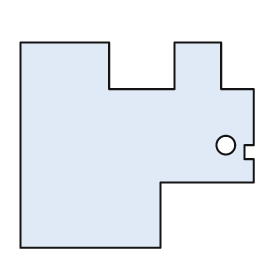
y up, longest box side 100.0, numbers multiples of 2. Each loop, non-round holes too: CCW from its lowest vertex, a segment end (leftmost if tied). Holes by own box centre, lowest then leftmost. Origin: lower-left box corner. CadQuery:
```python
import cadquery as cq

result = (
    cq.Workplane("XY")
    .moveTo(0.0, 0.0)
    .lineTo(60.0, 0.0)
    .lineTo(60.0, 28.0)
    .lineTo(100.0, 28.0)
    .lineTo(100.0, 38.0)
    .lineTo(96.0, 38.0)
    .lineTo(96.0, 44.0)
    .lineTo(100.0, 44.0)
    .lineTo(100.0, 68.0)
    .lineTo(86.0, 68.0)
    .lineTo(86.0, 88.0)
    .lineTo(66.0, 88.0)
    .lineTo(66.0, 68.0)
    .lineTo(38.0, 68.0)
    .lineTo(38.0, 88.0)
    .lineTo(0.0, 88.0)
    .close()
    .moveTo(88.0, 44.0)
    .circle(4.0)
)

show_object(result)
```